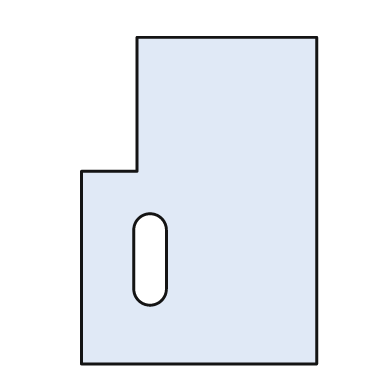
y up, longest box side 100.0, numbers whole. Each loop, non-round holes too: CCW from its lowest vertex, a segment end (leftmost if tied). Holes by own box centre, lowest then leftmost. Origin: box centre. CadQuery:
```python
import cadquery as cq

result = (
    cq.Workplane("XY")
    .moveTo(-36.0, -50.0)
    .lineTo(36.0, -50.0)
    .lineTo(36.0, 50.0)
    .lineTo(-19.0, 50.0)
    .lineTo(-19.0, 9.0)
    .lineTo(-36.0, 9.0)
    .close()
    .moveTo(-20.0, -27.0)
    .threePointArc((-15.0, -32.0), (-10.0, -27.0))
    .lineTo(-10.0, -9.0)
    .threePointArc((-15.0, -4.0), (-20.0, -9.0))
    .close()
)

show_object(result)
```